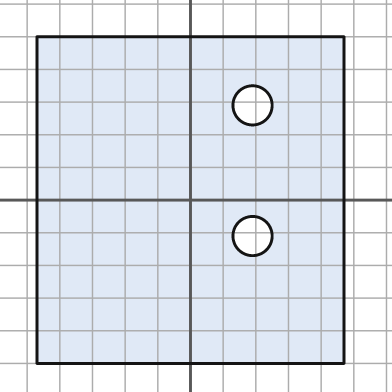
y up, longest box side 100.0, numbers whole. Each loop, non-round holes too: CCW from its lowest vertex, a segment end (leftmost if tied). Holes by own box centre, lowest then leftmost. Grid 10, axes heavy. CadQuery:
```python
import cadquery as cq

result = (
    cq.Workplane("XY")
    .moveTo(-47.0, -50.0)
    .lineTo(47.0, -50.0)
    .lineTo(47.0, 50.0)
    .lineTo(-47.0, 50.0)
    .close()
    .moveTo(19.0, -11.0)
    .circle(6.0)
    .moveTo(19.0, 29.0)
    .circle(6.0)
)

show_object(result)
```